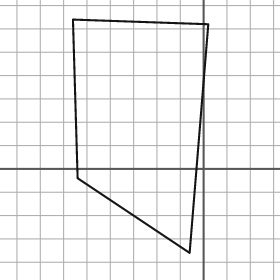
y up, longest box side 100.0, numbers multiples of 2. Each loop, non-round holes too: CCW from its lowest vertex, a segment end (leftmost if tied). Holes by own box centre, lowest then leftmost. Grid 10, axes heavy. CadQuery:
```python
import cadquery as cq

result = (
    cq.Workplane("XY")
    .moveTo(-6.0, -36.0)
    .lineTo(2.0, 62.0)
    .lineTo(-56.0, 64.0)
    .lineTo(-54.0, -4.0)
    .close()
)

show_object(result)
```